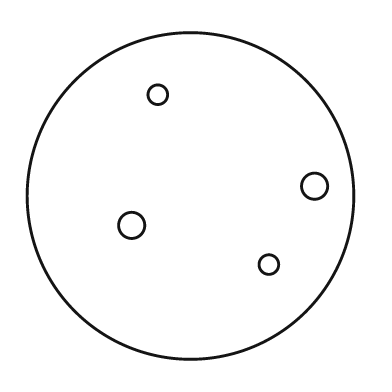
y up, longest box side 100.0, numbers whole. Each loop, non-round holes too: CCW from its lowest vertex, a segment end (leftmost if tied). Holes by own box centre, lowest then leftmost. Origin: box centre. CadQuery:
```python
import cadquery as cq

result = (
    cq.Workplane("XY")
    .moveTo(0.0, 0.0)
    .circle(50.0)
    .moveTo(24.0, -21.0)
    .circle(3.0)
    .moveTo(-18.0, -9.0)
    .circle(4.0)
    .moveTo(38.0, 3.0)
    .circle(4.0)
    .moveTo(-10.0, 31.0)
    .circle(3.0)
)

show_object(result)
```